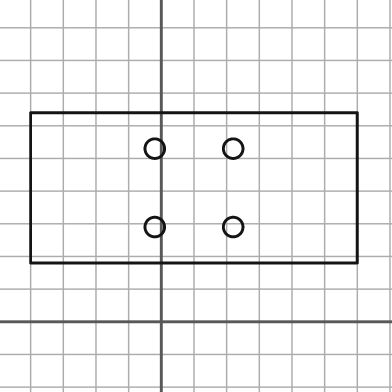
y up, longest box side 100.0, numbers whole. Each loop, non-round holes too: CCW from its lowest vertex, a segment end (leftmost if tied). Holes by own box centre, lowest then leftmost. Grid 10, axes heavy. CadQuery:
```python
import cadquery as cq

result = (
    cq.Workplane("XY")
    .moveTo(-40.0, 18.0)
    .lineTo(60.0, 18.0)
    .lineTo(60.0, 64.0)
    .lineTo(-40.0, 64.0)
    .close()
    .moveTo(-2.0, 29.0)
    .circle(3.0)
    .moveTo(22.0, 29.0)
    .circle(3.0)
    .moveTo(-2.0, 53.0)
    .circle(3.0)
    .moveTo(22.0, 53.0)
    .circle(3.0)
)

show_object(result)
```